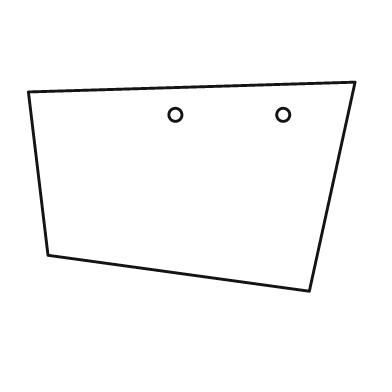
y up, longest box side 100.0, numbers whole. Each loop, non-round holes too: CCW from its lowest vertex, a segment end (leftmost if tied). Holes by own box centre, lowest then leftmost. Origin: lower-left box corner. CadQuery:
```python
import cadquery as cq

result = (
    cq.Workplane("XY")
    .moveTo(86.0, 0.0)
    .lineTo(100.0, 64.0)
    .lineTo(0.0, 61.0)
    .lineTo(6.0, 11.0)
    .close()
    .moveTo(45.0, 54.0)
    .circle(2.0)
    .moveTo(78.0, 54.0)
    .circle(2.0)
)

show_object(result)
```